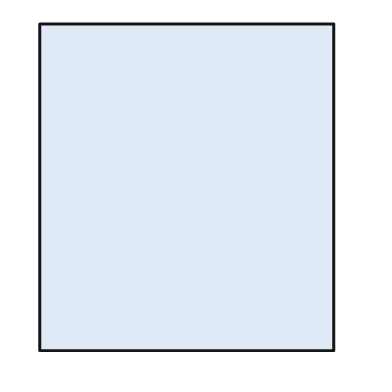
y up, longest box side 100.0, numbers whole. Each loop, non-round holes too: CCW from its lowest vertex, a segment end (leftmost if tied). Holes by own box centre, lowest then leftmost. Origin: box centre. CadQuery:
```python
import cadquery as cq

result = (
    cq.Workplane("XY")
    .moveTo(-45.0, -50.0)
    .lineTo(45.0, -50.0)
    .lineTo(45.0, 50.0)
    .lineTo(-45.0, 50.0)
    .close()
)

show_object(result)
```